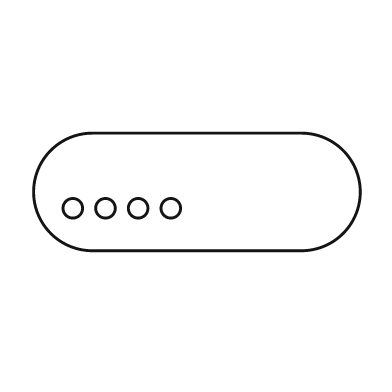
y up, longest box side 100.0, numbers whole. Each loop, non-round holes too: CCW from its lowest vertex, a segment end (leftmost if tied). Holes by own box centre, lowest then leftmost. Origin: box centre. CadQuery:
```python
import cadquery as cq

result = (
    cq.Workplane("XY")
    .moveTo(-32.0, -18.0)
    .lineTo(32.0, -18.0)
    .threePointArc((50.0, 0.0), (32.0, 18.0))
    .lineTo(-32.0, 18.0)
    .threePointArc((-50.0, 0.0), (-32.0, -18.0))
    .close()
    .moveTo(-38.0, -5.0)
    .circle(3.0)
    .moveTo(-28.0, -5.0)
    .circle(3.0)
    .moveTo(-18.0, -5.0)
    .circle(3.0)
    .moveTo(-8.0, -5.0)
    .circle(3.0)
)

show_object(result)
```